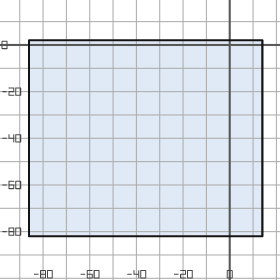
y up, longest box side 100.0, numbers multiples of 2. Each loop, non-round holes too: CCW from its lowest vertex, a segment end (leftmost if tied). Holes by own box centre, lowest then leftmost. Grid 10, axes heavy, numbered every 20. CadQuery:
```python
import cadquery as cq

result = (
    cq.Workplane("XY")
    .moveTo(-86.0, -82.0)
    .lineTo(14.0, -82.0)
    .lineTo(14.0, 2.0)
    .lineTo(-86.0, 2.0)
    .close()
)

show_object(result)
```